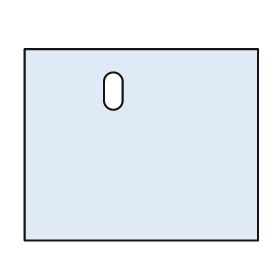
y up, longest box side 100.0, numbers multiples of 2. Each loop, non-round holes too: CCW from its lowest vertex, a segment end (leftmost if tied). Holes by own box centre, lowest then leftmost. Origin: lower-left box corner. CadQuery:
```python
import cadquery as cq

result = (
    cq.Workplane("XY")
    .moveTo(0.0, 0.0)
    .lineTo(100.0, 0.0)
    .lineTo(100.0, 82.0)
    .lineTo(0.0, 82.0)
    .close()
    .moveTo(34.0, 60.0)
    .threePointArc((38.0, 56.0), (42.0, 60.0))
    .lineTo(42.0, 68.0)
    .threePointArc((38.0, 72.0), (34.0, 68.0))
    .close()
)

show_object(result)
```